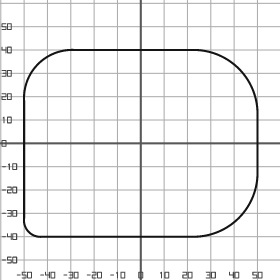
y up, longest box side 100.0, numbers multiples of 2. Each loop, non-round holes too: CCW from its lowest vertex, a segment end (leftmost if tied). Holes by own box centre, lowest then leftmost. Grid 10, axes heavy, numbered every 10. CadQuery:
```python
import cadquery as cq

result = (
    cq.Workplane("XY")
    .moveTo(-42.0, -40.0)
    .lineTo(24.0, -40.0)
    .threePointArc((42.0, -32.0), (50.0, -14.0))
    .lineTo(50.0, 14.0)
    .threePointArc((42.0, 32.0), (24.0, 40.0))
    .lineTo(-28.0, 40.0)
    .threePointArc((-44.0, 34.0), (-50.0, 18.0))
    .lineTo(-50.0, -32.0)
    .threePointArc((-48.0, -38.0), (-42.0, -40.0))
    .close()
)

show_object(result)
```